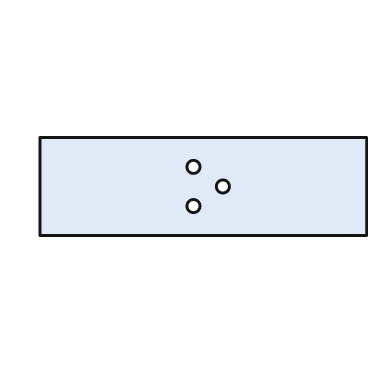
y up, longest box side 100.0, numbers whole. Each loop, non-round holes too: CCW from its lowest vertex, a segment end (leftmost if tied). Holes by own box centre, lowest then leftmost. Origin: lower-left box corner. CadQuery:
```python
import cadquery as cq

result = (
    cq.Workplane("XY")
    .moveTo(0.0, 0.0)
    .lineTo(100.0, 0.0)
    .lineTo(100.0, 30.0)
    .lineTo(0.0, 30.0)
    .close()
    .moveTo(47.0, 9.0)
    .circle(2.0)
    .moveTo(56.0, 15.0)
    .circle(2.0)
    .moveTo(47.0, 21.0)
    .circle(2.0)
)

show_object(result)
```